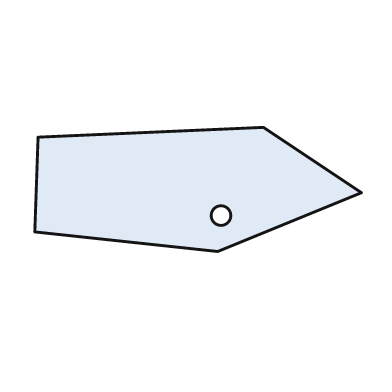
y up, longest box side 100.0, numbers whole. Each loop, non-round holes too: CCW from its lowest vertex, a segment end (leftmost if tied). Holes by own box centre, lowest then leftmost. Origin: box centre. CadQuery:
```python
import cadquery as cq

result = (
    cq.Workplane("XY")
    .moveTo(6.0, -19.0)
    .lineTo(50.0, -1.0)
    .lineTo(20.0, 19.0)
    .lineTo(-49.0, 16.0)
    .lineTo(-50.0, -13.0)
    .close()
    .moveTo(7.0, -8.0)
    .circle(3.0)
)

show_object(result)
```